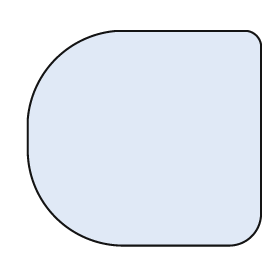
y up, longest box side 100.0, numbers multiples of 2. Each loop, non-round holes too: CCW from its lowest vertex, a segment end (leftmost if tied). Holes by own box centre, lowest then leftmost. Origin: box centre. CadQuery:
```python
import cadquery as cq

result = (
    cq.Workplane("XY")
    .moveTo(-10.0, -46.0)
    .lineTo(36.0, -46.0)
    .threePointArc((46.0, -42.0), (50.0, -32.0))
    .lineTo(50.0, 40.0)
    .threePointArc((48.0, 44.0), (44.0, 46.0))
    .lineTo(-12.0, 46.0)
    .threePointArc((-38.0, 34.0), (-50.0, 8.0))
    .lineTo(-50.0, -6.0)
    .threePointArc((-38.0, -34.0), (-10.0, -46.0))
    .close()
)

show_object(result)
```